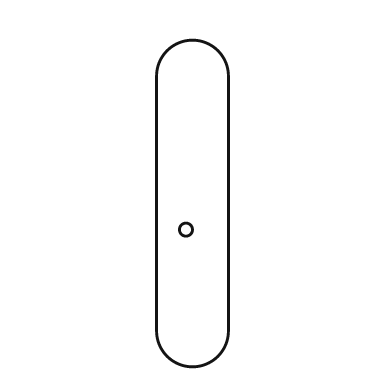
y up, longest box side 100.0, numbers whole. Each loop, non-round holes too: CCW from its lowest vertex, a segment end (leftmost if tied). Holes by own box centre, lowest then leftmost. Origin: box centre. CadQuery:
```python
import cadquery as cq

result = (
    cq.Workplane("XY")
    .moveTo(-11.0, -39.0)
    .threePointArc((0.0, -50.0), (11.0, -39.0))
    .lineTo(11.0, 39.0)
    .threePointArc((0.0, 50.0), (-11.0, 39.0))
    .close()
    .moveTo(-2.0, -8.0)
    .circle(2.0)
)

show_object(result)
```